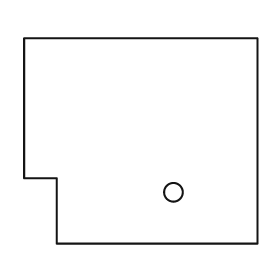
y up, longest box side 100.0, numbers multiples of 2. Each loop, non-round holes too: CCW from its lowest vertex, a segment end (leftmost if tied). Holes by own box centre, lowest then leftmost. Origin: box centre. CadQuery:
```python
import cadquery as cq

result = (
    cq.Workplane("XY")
    .moveTo(-36.0, -44.0)
    .lineTo(50.0, -44.0)
    .lineTo(50.0, 44.0)
    .lineTo(-50.0, 44.0)
    .lineTo(-50.0, -16.0)
    .lineTo(-36.0, -16.0)
    .close()
    .moveTo(14.0, -22.0)
    .circle(4.0)
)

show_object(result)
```